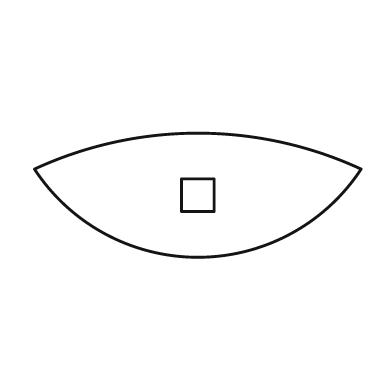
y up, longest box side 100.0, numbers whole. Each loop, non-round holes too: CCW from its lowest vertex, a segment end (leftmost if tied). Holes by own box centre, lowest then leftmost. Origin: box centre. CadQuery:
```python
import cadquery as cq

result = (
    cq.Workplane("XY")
    .moveTo(-50.0, 8.0)
    .threePointArc((0.0, -19.0), (50.0, 8.0))
    .threePointArc((0.0, 19.0), (-50.0, 8.0))
    .close()
    .moveTo(-5.0, -5.0)
    .lineTo(5.0, -5.0)
    .lineTo(5.0, 5.0)
    .lineTo(-5.0, 5.0)
    .close()
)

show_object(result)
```